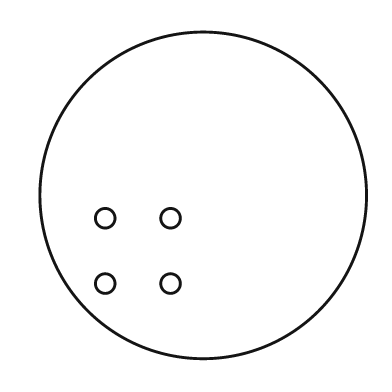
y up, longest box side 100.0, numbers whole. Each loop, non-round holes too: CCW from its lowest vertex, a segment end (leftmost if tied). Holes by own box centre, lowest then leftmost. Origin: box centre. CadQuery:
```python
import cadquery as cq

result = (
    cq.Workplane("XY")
    .moveTo(0.0, 0.0)
    .circle(50.0)
    .moveTo(-30.0, -27.0)
    .circle(3.0)
    .moveTo(-10.0, -27.0)
    .circle(3.0)
    .moveTo(-30.0, -7.0)
    .circle(3.0)
    .moveTo(-10.0, -7.0)
    .circle(3.0)
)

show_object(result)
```